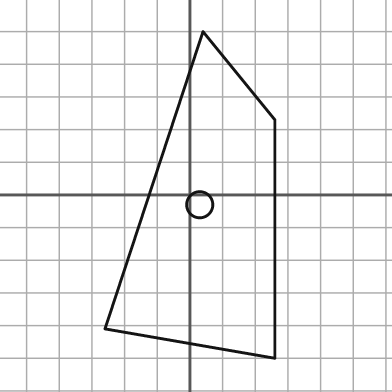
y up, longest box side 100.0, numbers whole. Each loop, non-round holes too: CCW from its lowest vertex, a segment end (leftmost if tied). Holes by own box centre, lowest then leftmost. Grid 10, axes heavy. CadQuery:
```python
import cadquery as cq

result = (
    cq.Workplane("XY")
    .moveTo(26.0, -50.0)
    .lineTo(26.0, 23.0)
    .lineTo(4.0, 50.0)
    .lineTo(-26.0, -41.0)
    .close()
    .moveTo(3.0, -3.0)
    .circle(4.0)
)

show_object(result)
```